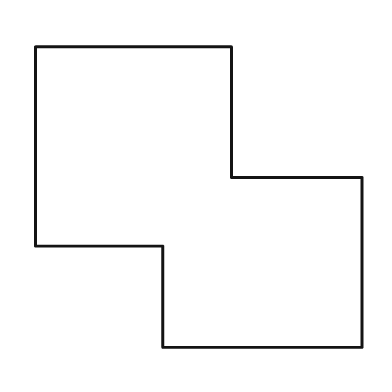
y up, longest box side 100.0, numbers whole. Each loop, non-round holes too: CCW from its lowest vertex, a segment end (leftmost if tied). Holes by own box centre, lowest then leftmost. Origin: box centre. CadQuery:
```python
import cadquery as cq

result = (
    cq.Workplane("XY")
    .moveTo(-11.0, -46.0)
    .lineTo(50.0, -46.0)
    .lineTo(50.0, 6.0)
    .lineTo(10.0, 6.0)
    .lineTo(10.0, 46.0)
    .lineTo(-50.0, 46.0)
    .lineTo(-50.0, -15.0)
    .lineTo(-11.0, -15.0)
    .close()
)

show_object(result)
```